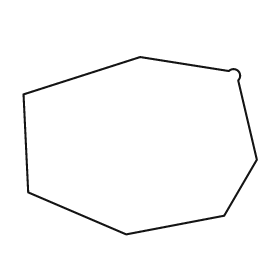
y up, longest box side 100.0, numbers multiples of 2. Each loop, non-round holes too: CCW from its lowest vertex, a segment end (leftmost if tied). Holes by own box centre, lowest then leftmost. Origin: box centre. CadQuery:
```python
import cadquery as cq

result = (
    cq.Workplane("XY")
    .moveTo(-6.0, -38.0)
    .lineTo(36.0, -30.0)
    .lineTo(50.0, -6.0)
    .lineTo(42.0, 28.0)
    .threePointArc((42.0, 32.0), (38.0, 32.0))
    .lineTo(0.0, 38.0)
    .lineTo(-50.0, 22.0)
    .lineTo(-48.0, -20.0)
    .close()
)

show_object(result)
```